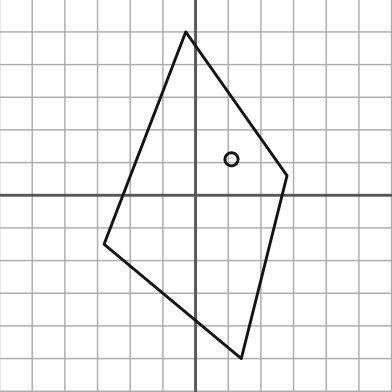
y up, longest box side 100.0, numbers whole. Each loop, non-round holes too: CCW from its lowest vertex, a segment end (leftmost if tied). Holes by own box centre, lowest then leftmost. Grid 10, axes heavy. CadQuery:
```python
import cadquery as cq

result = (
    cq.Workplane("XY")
    .moveTo(14.0, -50.0)
    .lineTo(28.0, 6.0)
    .lineTo(-3.0, 50.0)
    .lineTo(-28.0, -15.0)
    .close()
    .moveTo(11.0, 11.0)
    .circle(2.0)
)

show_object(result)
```